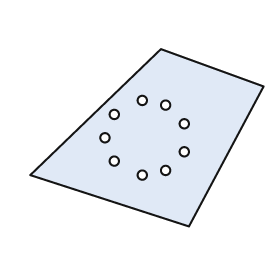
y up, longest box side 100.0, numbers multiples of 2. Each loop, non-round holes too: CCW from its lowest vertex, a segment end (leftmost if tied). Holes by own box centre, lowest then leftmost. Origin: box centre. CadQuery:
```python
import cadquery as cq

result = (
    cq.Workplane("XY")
    .moveTo(18.0, -38.0)
    .lineTo(50.0, 22.0)
    .lineTo(6.0, 38.0)
    .lineTo(-50.0, -16.0)
    .close()
    .moveTo(-2.0, -16.0)
    .circle(2.0)
    .moveTo(8.0, -14.0)
    .circle(2.0)
    .moveTo(-14.0, -10.0)
    .circle(2.0)
    .moveTo(16.0, -6.0)
    .circle(2.0)
    .moveTo(-18.0, 0.0)
    .circle(2.0)
    .moveTo(16.0, 6.0)
    .circle(2.0)
    .moveTo(-14.0, 10.0)
    .circle(2.0)
    .moveTo(8.0, 14.0)
    .circle(2.0)
    .moveTo(-2.0, 16.0)
    .circle(2.0)
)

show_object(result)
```